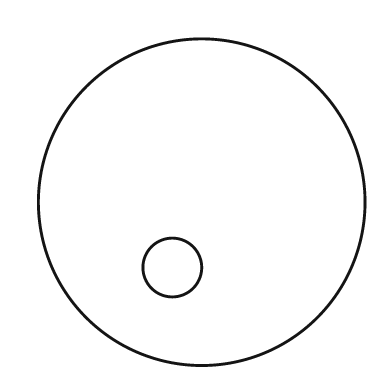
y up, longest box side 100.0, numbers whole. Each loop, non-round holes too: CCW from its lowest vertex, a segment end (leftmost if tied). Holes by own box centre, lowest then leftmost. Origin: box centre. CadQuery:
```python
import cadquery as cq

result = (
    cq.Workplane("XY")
    .moveTo(0.0, 0.0)
    .circle(50.0)
    .moveTo(-9.0, -20.0)
    .circle(9.0)
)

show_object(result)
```